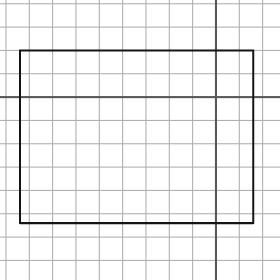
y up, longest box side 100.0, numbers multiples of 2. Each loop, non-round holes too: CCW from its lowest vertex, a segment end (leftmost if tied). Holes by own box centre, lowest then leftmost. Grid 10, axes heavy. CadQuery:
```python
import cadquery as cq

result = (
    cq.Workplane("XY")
    .moveTo(-84.0, -54.0)
    .lineTo(16.0, -54.0)
    .lineTo(16.0, 20.0)
    .lineTo(-84.0, 20.0)
    .close()
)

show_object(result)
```